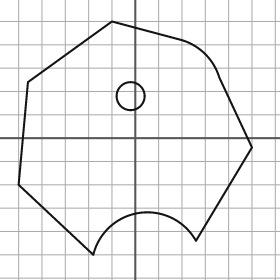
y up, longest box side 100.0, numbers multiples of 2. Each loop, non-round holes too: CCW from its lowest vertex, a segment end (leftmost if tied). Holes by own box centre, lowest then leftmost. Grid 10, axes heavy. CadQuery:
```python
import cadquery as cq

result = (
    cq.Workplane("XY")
    .moveTo(-18.0, -50.0)
    .threePointArc((2.0, -32.0), (26.0, -44.0))
    .lineTo(50.0, -4.0)
    .lineTo(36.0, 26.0)
    .threePointArc((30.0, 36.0), (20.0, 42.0))
    .lineTo(-10.0, 50.0)
    .lineTo(-46.0, 24.0)
    .lineTo(-50.0, -20.0)
    .close()
    .moveTo(-2.0, 18.0)
    .circle(6.0)
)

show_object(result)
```